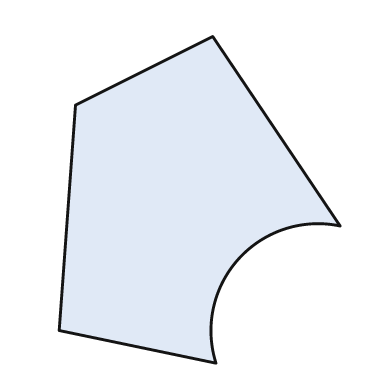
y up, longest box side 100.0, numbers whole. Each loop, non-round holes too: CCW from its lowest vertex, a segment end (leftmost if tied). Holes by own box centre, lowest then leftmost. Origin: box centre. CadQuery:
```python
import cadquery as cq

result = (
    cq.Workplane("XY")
    .moveTo(5.0, -50.0)
    .threePointArc((12.0, -18.0), (43.0, -8.0))
    .lineTo(4.0, 50.0)
    .lineTo(-38.0, 29.0)
    .lineTo(-43.0, -40.0)
    .close()
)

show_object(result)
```